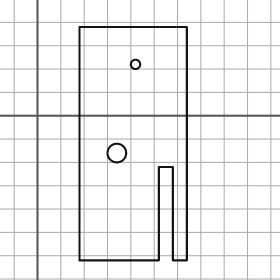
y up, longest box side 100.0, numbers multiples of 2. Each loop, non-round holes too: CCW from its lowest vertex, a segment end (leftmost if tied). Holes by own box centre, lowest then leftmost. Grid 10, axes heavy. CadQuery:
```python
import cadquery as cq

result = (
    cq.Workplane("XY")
    .moveTo(18.0, -62.0)
    .lineTo(52.0, -62.0)
    .lineTo(52.0, -22.0)
    .lineTo(58.0, -22.0)
    .lineTo(58.0, -62.0)
    .lineTo(64.0, -62.0)
    .lineTo(64.0, 38.0)
    .lineTo(18.0, 38.0)
    .close()
    .moveTo(34.0, -16.0)
    .circle(4.0)
    .moveTo(42.0, 22.0)
    .circle(2.0)
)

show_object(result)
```